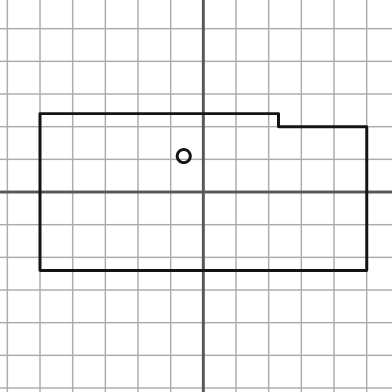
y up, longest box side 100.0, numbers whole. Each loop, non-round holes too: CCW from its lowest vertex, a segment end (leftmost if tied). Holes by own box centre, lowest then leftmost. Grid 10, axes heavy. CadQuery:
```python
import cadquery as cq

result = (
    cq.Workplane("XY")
    .moveTo(-50.0, -24.0)
    .lineTo(50.0, -24.0)
    .lineTo(50.0, 20.0)
    .lineTo(23.0, 20.0)
    .lineTo(23.0, 24.0)
    .lineTo(-50.0, 24.0)
    .close()
    .moveTo(-6.0, 11.0)
    .circle(2.0)
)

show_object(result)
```